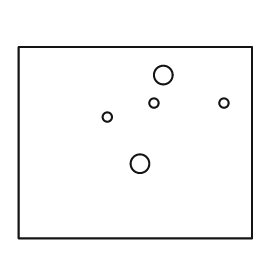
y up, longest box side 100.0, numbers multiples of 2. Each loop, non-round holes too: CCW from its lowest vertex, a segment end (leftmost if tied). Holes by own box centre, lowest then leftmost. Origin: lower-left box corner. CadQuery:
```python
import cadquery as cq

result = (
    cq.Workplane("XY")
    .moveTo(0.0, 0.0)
    .lineTo(100.0, 0.0)
    .lineTo(100.0, 82.0)
    .lineTo(0.0, 82.0)
    .close()
    .moveTo(52.0, 32.0)
    .circle(4.0)
    .moveTo(38.0, 52.0)
    .circle(2.0)
    .moveTo(58.0, 58.0)
    .circle(2.0)
    .moveTo(88.0, 58.0)
    .circle(2.0)
    .moveTo(62.0, 70.0)
    .circle(4.0)
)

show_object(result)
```